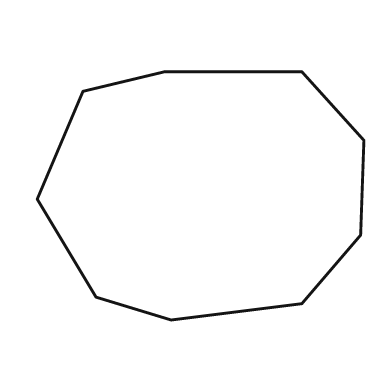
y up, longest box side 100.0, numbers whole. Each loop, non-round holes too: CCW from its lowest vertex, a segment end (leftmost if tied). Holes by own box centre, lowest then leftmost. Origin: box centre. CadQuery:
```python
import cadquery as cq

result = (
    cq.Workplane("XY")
    .moveTo(-9.0, -38.0)
    .lineTo(31.0, -33.0)
    .lineTo(49.0, -12.0)
    .lineTo(50.0, 17.0)
    .lineTo(31.0, 38.0)
    .lineTo(-11.0, 38.0)
    .lineTo(-36.0, 32.0)
    .lineTo(-50.0, -1.0)
    .lineTo(-32.0, -31.0)
    .close()
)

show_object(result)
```